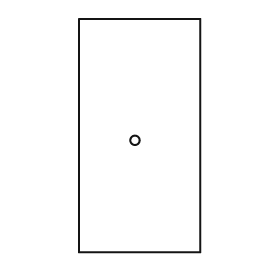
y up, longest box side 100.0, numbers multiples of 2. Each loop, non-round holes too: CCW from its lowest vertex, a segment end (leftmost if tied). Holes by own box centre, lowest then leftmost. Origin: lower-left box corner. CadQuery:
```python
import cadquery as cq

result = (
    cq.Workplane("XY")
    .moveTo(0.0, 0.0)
    .lineTo(52.0, 0.0)
    .lineTo(52.0, 100.0)
    .lineTo(0.0, 100.0)
    .close()
    .moveTo(24.0, 48.0)
    .circle(2.0)
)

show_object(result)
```